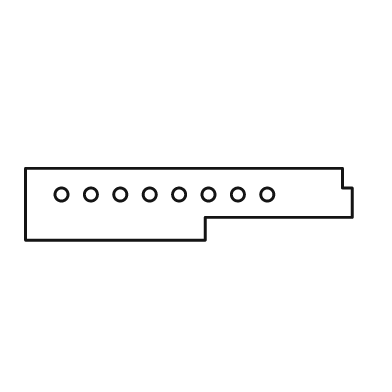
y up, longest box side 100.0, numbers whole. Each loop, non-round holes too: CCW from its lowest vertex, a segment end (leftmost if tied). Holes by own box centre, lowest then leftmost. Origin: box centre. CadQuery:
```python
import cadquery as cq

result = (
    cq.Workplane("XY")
    .moveTo(-50.0, -11.0)
    .lineTo(5.0, -11.0)
    .lineTo(5.0, -4.0)
    .lineTo(50.0, -4.0)
    .lineTo(50.0, 5.0)
    .lineTo(47.0, 5.0)
    .lineTo(47.0, 11.0)
    .lineTo(-50.0, 11.0)
    .close()
    .moveTo(-39.0, 3.0)
    .circle(2.0)
    .moveTo(-30.0, 3.0)
    .circle(2.0)
    .moveTo(-21.0, 3.0)
    .circle(2.0)
    .moveTo(-12.0, 3.0)
    .circle(2.0)
    .moveTo(-3.0, 3.0)
    .circle(2.0)
    .moveTo(6.0, 3.0)
    .circle(2.0)
    .moveTo(15.0, 3.0)
    .circle(2.0)
    .moveTo(24.0, 3.0)
    .circle(2.0)
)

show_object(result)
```